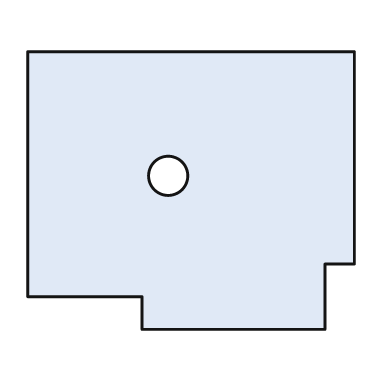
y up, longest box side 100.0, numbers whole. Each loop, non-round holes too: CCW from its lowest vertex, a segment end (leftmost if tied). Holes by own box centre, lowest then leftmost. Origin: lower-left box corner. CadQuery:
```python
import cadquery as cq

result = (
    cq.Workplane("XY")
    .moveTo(35.0, 0.0)
    .lineTo(91.0, 0.0)
    .lineTo(91.0, 20.0)
    .lineTo(100.0, 20.0)
    .lineTo(100.0, 85.0)
    .lineTo(0.0, 85.0)
    .lineTo(0.0, 10.0)
    .lineTo(35.0, 10.0)
    .close()
    .moveTo(43.0, 47.0)
    .circle(6.0)
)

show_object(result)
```